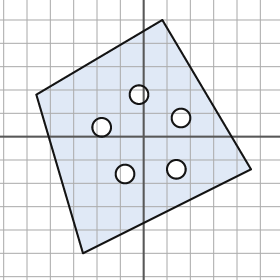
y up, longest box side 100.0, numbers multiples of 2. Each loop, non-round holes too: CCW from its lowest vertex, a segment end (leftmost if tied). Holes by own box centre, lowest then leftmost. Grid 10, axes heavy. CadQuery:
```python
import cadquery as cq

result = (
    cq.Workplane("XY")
    .moveTo(-26.0, -50.0)
    .lineTo(46.0, -14.0)
    .lineTo(8.0, 50.0)
    .lineTo(-46.0, 18.0)
    .close()
    .moveTo(-8.0, -16.0)
    .circle(4.0)
    .moveTo(14.0, -14.0)
    .circle(4.0)
    .moveTo(-18.0, 4.0)
    .circle(4.0)
    .moveTo(16.0, 8.0)
    .circle(4.0)
    .moveTo(-2.0, 18.0)
    .circle(4.0)
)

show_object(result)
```